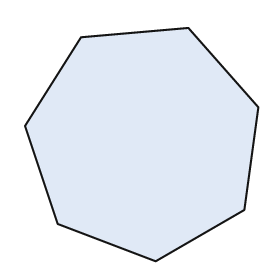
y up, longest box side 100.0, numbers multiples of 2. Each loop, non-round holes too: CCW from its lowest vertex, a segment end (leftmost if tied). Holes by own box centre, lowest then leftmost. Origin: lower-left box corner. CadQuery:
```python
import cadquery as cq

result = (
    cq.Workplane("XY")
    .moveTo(56.0, 0.0)
    .lineTo(94.0, 22.0)
    .lineTo(100.0, 66.0)
    .lineTo(70.0, 100.0)
    .lineTo(24.0, 96.0)
    .lineTo(0.0, 58.0)
    .lineTo(14.0, 16.0)
    .close()
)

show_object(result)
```